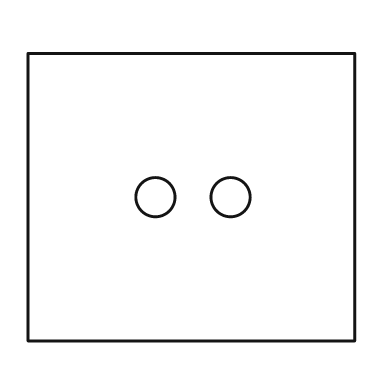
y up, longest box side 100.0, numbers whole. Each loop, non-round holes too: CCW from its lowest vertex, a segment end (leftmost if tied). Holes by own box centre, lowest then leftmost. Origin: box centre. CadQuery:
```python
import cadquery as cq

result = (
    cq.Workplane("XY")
    .moveTo(-50.0, -44.0)
    .lineTo(50.0, -44.0)
    .lineTo(50.0, 44.0)
    .lineTo(-50.0, 44.0)
    .close()
    .moveTo(-11.0, 0.0)
    .circle(6.0)
    .moveTo(12.0, 0.0)
    .circle(6.0)
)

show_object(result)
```